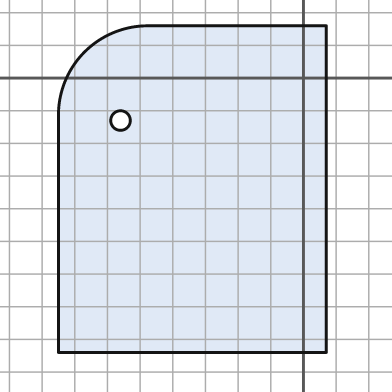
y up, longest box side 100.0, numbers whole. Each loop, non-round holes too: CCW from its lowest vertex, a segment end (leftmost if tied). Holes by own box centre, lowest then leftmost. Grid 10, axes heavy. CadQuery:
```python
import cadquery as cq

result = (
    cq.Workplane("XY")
    .moveTo(-75.0, -84.0)
    .lineTo(7.0, -84.0)
    .lineTo(7.0, 16.0)
    .lineTo(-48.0, 16.0)
    .threePointArc((-67.0, 8.0), (-75.0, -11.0))
    .close()
    .moveTo(-56.0, -13.0)
    .circle(3.0)
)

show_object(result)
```